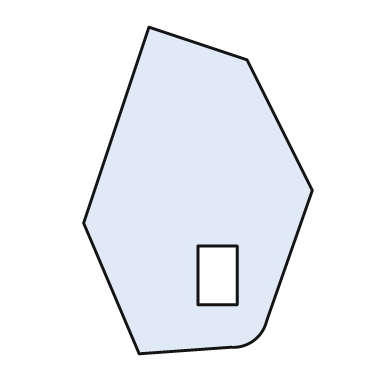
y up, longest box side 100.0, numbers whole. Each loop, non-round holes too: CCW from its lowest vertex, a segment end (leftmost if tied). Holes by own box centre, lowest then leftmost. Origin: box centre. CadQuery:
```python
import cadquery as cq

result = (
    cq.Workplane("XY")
    .moveTo(-18.0, -50.0)
    .lineTo(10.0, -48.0)
    .threePointArc((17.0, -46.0), (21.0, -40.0))
    .lineTo(35.0, 0.0)
    .lineTo(15.0, 40.0)
    .lineTo(-15.0, 50.0)
    .lineTo(-35.0, -10.0)
    .close()
    .moveTo(0.0, -35.0)
    .lineTo(12.0, -35.0)
    .lineTo(12.0, -17.0)
    .lineTo(0.0, -17.0)
    .close()
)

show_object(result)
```